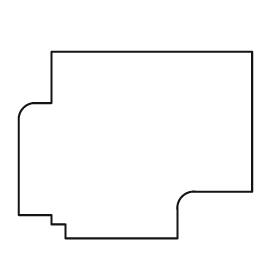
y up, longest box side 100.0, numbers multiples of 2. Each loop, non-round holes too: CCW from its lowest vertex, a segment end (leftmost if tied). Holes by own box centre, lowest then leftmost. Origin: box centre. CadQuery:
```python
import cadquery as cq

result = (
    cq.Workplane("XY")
    .moveTo(-30.0, -40.0)
    .lineTo(18.0, -40.0)
    .lineTo(18.0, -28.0)
    .threePointArc((20.0, -22.0), (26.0, -20.0))
    .lineTo(50.0, -20.0)
    .lineTo(50.0, 40.0)
    .lineTo(-36.0, 40.0)
    .lineTo(-36.0, 18.0)
    .lineTo(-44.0, 18.0)
    .threePointArc((-48.0, 16.0), (-50.0, 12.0))
    .lineTo(-50.0, -30.0)
    .lineTo(-36.0, -30.0)
    .lineTo(-36.0, -34.0)
    .lineTo(-30.0, -34.0)
    .close()
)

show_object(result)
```